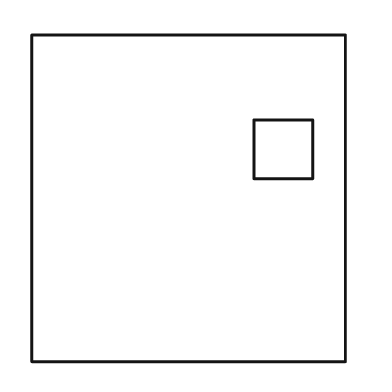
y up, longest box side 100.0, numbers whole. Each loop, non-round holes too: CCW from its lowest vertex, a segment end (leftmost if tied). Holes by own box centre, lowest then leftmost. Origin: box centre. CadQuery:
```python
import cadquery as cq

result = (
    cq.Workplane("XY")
    .moveTo(-48.0, -50.0)
    .lineTo(48.0, -50.0)
    .lineTo(48.0, 50.0)
    .lineTo(-48.0, 50.0)
    .close()
    .moveTo(20.0, 6.0)
    .lineTo(38.0, 6.0)
    .lineTo(38.0, 24.0)
    .lineTo(20.0, 24.0)
    .close()
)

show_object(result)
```